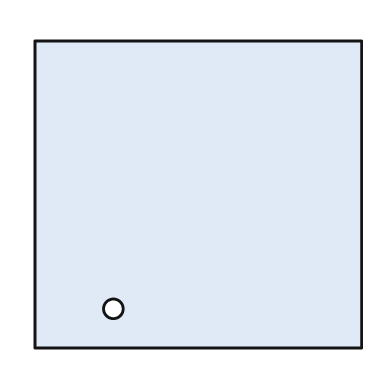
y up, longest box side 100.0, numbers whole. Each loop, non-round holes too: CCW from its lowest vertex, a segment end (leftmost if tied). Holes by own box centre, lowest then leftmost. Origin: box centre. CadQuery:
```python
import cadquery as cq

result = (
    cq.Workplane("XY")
    .moveTo(-50.0, -47.0)
    .lineTo(50.0, -47.0)
    .lineTo(50.0, 47.0)
    .lineTo(-50.0, 47.0)
    .close()
    .moveTo(-26.0, -35.0)
    .circle(3.0)
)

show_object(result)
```